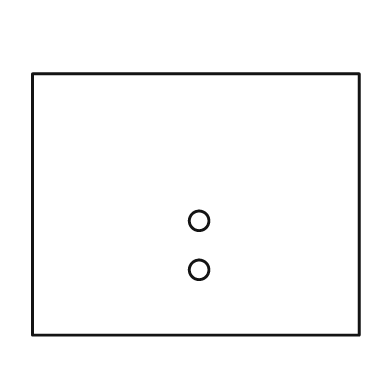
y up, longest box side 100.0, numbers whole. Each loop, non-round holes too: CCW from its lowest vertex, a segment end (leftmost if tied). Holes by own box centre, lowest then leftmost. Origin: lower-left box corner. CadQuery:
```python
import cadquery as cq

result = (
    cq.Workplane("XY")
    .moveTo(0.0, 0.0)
    .lineTo(100.0, 0.0)
    .lineTo(100.0, 80.0)
    .lineTo(0.0, 80.0)
    .close()
    .moveTo(51.0, 20.0)
    .circle(3.0)
    .moveTo(51.0, 35.0)
    .circle(3.0)
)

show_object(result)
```